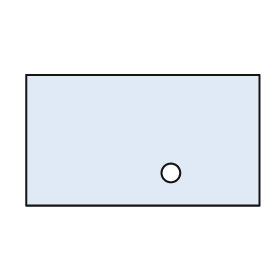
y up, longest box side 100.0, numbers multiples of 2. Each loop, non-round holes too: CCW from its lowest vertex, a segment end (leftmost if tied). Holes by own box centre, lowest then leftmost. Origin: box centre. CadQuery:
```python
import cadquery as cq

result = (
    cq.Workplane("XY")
    .moveTo(-50.0, -28.0)
    .lineTo(50.0, -28.0)
    .lineTo(50.0, 28.0)
    .lineTo(-50.0, 28.0)
    .close()
    .moveTo(12.0, -14.0)
    .circle(4.0)
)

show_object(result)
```